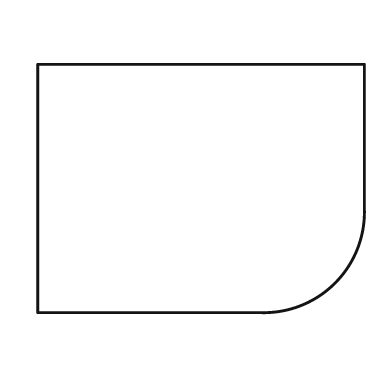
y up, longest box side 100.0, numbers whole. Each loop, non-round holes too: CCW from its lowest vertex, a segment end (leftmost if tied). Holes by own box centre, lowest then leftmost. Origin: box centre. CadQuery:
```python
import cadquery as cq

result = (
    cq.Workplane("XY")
    .moveTo(-50.0, -38.0)
    .lineTo(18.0, -38.0)
    .threePointArc((41.0, -29.0), (50.0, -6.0))
    .lineTo(50.0, 38.0)
    .lineTo(-50.0, 38.0)
    .close()
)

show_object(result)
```